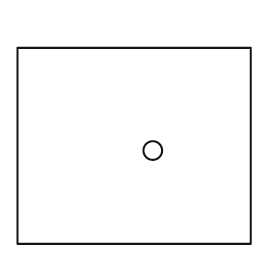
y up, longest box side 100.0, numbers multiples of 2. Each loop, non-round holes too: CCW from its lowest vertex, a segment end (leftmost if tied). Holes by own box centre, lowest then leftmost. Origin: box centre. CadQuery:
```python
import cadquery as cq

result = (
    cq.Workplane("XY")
    .moveTo(-50.0, -42.0)
    .lineTo(50.0, -42.0)
    .lineTo(50.0, 42.0)
    .lineTo(-50.0, 42.0)
    .close()
    .moveTo(8.0, -2.0)
    .circle(4.0)
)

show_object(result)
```